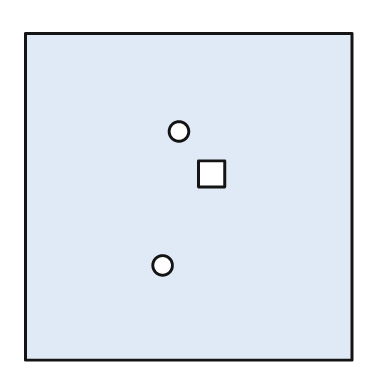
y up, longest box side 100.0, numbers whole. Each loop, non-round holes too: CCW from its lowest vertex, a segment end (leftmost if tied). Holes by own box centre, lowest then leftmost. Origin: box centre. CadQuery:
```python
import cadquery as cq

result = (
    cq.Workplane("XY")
    .moveTo(-50.0, -50.0)
    .lineTo(50.0, -50.0)
    .lineTo(50.0, 50.0)
    .lineTo(-50.0, 50.0)
    .close()
    .moveTo(-8.0, -21.0)
    .circle(3.0)
    .moveTo(3.0, 3.0)
    .lineTo(11.0, 3.0)
    .lineTo(11.0, 11.0)
    .lineTo(3.0, 11.0)
    .close()
    .moveTo(-3.0, 20.0)
    .circle(3.0)
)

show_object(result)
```